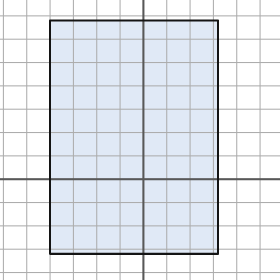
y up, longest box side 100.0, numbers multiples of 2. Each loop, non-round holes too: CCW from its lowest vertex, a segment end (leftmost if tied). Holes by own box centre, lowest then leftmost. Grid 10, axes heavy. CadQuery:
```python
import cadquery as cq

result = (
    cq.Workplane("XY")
    .moveTo(-40.0, -32.0)
    .lineTo(32.0, -32.0)
    .lineTo(32.0, 68.0)
    .lineTo(-40.0, 68.0)
    .close()
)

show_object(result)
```